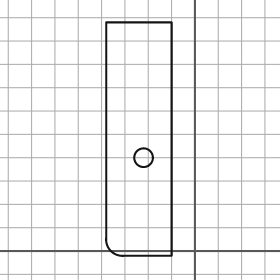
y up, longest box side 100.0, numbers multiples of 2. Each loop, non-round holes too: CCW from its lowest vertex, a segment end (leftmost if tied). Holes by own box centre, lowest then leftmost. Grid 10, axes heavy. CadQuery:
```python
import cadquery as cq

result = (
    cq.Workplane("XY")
    .moveTo(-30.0, -2.0)
    .lineTo(-10.0, -2.0)
    .lineTo(-10.0, 98.0)
    .lineTo(-38.0, 98.0)
    .lineTo(-38.0, 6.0)
    .threePointArc((-36.0, 0.0), (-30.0, -2.0))
    .close()
    .moveTo(-22.0, 40.0)
    .circle(4.0)
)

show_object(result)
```